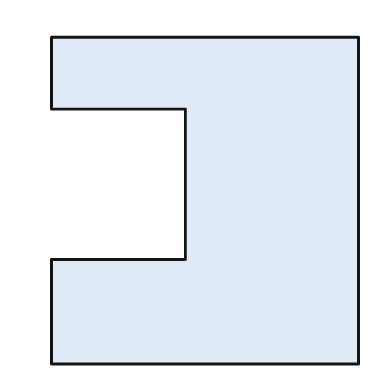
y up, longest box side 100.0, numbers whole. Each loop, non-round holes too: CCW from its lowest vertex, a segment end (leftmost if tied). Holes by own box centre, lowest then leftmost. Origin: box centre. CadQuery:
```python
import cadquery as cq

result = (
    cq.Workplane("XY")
    .moveTo(-47.0, -50.0)
    .lineTo(47.0, -50.0)
    .lineTo(47.0, 50.0)
    .lineTo(-47.0, 50.0)
    .lineTo(-47.0, 28.0)
    .lineTo(-6.0, 28.0)
    .lineTo(-6.0, -18.0)
    .lineTo(-47.0, -18.0)
    .close()
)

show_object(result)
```